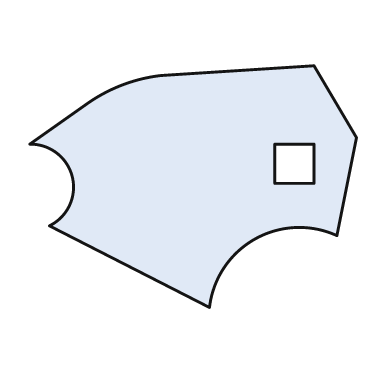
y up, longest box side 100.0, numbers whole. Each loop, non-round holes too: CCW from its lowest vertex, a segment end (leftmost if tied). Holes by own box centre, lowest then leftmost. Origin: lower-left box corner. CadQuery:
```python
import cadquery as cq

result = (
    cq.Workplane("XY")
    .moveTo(55.0, 0.0)
    .threePointArc((69.0, 21.0), (94.0, 22.0))
    .lineTo(100.0, 52.0)
    .lineTo(87.0, 74.0)
    .lineTo(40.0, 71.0)
    .threePointArc((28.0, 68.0), (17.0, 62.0))
    .lineTo(0.0, 50.0)
    .threePointArc((13.0, 40.0), (6.0, 25.0))
    .close()
    .moveTo(75.0, 38.0)
    .lineTo(87.0, 38.0)
    .lineTo(87.0, 50.0)
    .lineTo(75.0, 50.0)
    .close()
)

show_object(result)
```